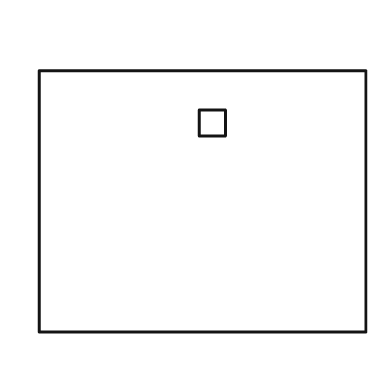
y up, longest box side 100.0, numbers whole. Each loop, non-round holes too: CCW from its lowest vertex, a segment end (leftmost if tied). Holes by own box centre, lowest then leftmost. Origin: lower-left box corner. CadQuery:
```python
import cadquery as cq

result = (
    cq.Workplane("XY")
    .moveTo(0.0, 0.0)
    .lineTo(100.0, 0.0)
    .lineTo(100.0, 80.0)
    .lineTo(0.0, 80.0)
    .close()
    .moveTo(49.0, 60.0)
    .lineTo(57.0, 60.0)
    .lineTo(57.0, 68.0)
    .lineTo(49.0, 68.0)
    .close()
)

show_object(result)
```